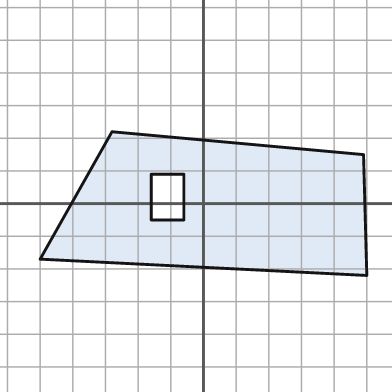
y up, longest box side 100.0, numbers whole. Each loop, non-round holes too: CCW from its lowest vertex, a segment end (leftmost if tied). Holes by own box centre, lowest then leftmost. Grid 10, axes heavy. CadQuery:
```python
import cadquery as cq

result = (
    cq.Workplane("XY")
    .moveTo(50.0, -22.0)
    .lineTo(49.0, 15.0)
    .lineTo(-28.0, 22.0)
    .lineTo(-50.0, -17.0)
    .close()
    .moveTo(-16.0, -5.0)
    .lineTo(-6.0, -5.0)
    .lineTo(-6.0, 9.0)
    .lineTo(-16.0, 9.0)
    .close()
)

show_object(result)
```